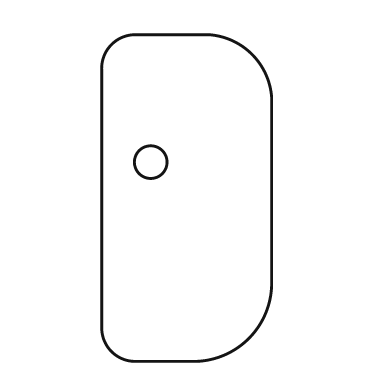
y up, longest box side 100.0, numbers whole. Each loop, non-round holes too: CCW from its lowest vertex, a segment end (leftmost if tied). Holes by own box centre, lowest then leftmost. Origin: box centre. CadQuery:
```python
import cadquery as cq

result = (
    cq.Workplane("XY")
    .moveTo(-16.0, -50.0)
    .lineTo(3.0, -50.0)
    .threePointArc((19.0, -43.0), (26.0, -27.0))
    .lineTo(26.0, 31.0)
    .threePointArc((20.0, 44.0), (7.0, 50.0))
    .lineTo(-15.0, 50.0)
    .threePointArc((-23.0, 47.0), (-26.0, 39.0))
    .lineTo(-26.0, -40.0)
    .threePointArc((-23.0, -47.0), (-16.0, -50.0))
    .close()
    .moveTo(-11.0, 11.0)
    .circle(5.0)
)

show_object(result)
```